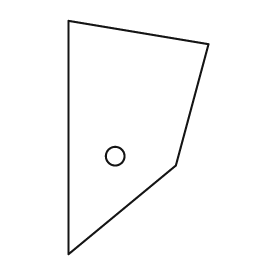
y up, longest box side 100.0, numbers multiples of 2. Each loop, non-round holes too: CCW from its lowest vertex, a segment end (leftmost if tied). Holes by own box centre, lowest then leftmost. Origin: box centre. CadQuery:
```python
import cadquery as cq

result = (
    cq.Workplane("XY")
    .moveTo(-30.0, -50.0)
    .lineTo(16.0, -12.0)
    .lineTo(30.0, 40.0)
    .lineTo(-30.0, 50.0)
    .close()
    .moveTo(-10.0, -8.0)
    .circle(4.0)
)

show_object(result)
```